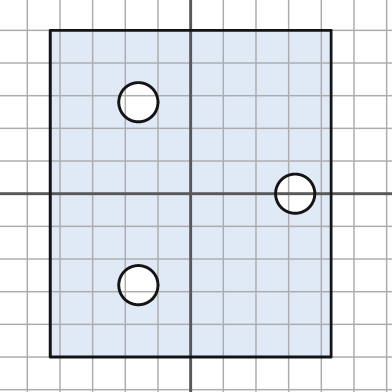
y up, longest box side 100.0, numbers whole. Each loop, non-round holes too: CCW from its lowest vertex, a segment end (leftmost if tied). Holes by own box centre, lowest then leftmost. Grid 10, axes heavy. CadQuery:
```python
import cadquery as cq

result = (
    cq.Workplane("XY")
    .moveTo(-43.0, -50.0)
    .lineTo(43.0, -50.0)
    .lineTo(43.0, 50.0)
    .lineTo(-43.0, 50.0)
    .close()
    .moveTo(-16.0, -28.0)
    .circle(6.0)
    .moveTo(32.0, 0.0)
    .circle(6.0)
    .moveTo(-16.0, 28.0)
    .circle(6.0)
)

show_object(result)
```